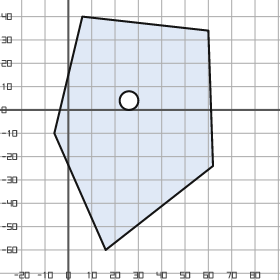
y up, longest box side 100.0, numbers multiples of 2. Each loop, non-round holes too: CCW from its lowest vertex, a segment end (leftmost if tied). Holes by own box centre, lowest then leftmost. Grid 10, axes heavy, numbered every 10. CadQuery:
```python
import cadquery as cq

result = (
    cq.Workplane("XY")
    .moveTo(16.0, -60.0)
    .lineTo(62.0, -24.0)
    .lineTo(60.0, 34.0)
    .lineTo(6.0, 40.0)
    .lineTo(-6.0, -10.0)
    .close()
    .moveTo(26.0, 4.0)
    .circle(4.0)
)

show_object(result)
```